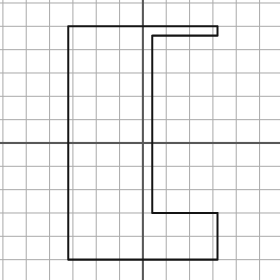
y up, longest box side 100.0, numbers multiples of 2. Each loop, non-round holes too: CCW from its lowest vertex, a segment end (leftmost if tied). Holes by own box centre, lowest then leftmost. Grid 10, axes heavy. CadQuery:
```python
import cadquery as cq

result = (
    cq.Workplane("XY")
    .moveTo(-32.0, -50.0)
    .lineTo(32.0, -50.0)
    .lineTo(32.0, -30.0)
    .lineTo(4.0, -30.0)
    .lineTo(4.0, 46.0)
    .lineTo(32.0, 46.0)
    .lineTo(32.0, 50.0)
    .lineTo(-32.0, 50.0)
    .close()
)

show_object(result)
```